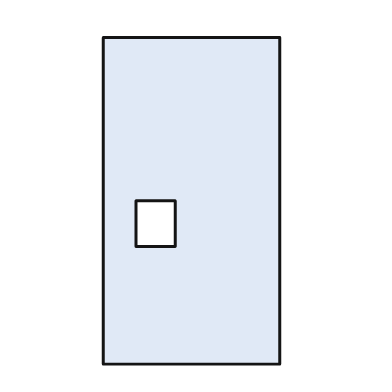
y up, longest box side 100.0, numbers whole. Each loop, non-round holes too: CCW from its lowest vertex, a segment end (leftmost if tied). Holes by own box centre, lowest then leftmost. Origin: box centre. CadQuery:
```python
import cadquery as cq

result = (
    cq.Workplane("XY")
    .moveTo(-27.0, -50.0)
    .lineTo(27.0, -50.0)
    .lineTo(27.0, 50.0)
    .lineTo(-27.0, 50.0)
    .close()
    .moveTo(-17.0, -14.0)
    .lineTo(-5.0, -14.0)
    .lineTo(-5.0, 0.0)
    .lineTo(-17.0, 0.0)
    .close()
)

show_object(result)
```